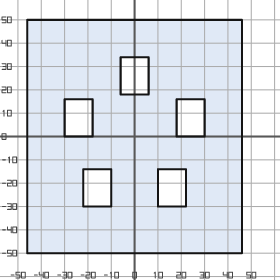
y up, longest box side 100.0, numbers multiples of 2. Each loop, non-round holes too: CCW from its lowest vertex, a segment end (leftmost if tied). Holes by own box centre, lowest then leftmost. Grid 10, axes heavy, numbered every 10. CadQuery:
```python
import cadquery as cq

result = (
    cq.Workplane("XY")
    .moveTo(-46.0, -50.0)
    .lineTo(46.0, -50.0)
    .lineTo(46.0, 50.0)
    .lineTo(-46.0, 50.0)
    .close()
    .moveTo(-22.0, -30.0)
    .lineTo(-10.0, -30.0)
    .lineTo(-10.0, -14.0)
    .lineTo(-22.0, -14.0)
    .close()
    .moveTo(10.0, -30.0)
    .lineTo(22.0, -30.0)
    .lineTo(22.0, -14.0)
    .lineTo(10.0, -14.0)
    .close()
    .moveTo(-30.0, 0.0)
    .lineTo(-18.0, 0.0)
    .lineTo(-18.0, 16.0)
    .lineTo(-30.0, 16.0)
    .close()
    .moveTo(18.0, 0.0)
    .lineTo(30.0, 0.0)
    .lineTo(30.0, 16.0)
    .lineTo(18.0, 16.0)
    .close()
    .moveTo(-6.0, 18.0)
    .lineTo(6.0, 18.0)
    .lineTo(6.0, 34.0)
    .lineTo(-6.0, 34.0)
    .close()
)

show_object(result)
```